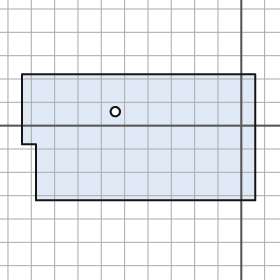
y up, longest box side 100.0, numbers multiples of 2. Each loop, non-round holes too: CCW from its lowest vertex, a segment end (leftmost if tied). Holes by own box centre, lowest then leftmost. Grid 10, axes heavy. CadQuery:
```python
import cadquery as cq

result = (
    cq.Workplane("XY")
    .moveTo(-88.0, -32.0)
    .lineTo(6.0, -32.0)
    .lineTo(6.0, 22.0)
    .lineTo(-94.0, 22.0)
    .lineTo(-94.0, -8.0)
    .lineTo(-88.0, -8.0)
    .close()
    .moveTo(-54.0, 6.0)
    .circle(2.0)
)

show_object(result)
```